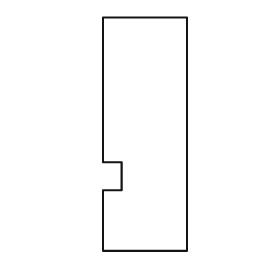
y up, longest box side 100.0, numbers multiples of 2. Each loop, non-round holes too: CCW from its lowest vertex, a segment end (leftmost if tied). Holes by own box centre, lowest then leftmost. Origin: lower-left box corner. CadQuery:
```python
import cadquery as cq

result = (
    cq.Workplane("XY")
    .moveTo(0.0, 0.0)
    .lineTo(36.0, 0.0)
    .lineTo(36.0, 100.0)
    .lineTo(0.0, 100.0)
    .lineTo(0.0, 38.0)
    .lineTo(8.0, 38.0)
    .lineTo(8.0, 26.0)
    .lineTo(0.0, 26.0)
    .close()
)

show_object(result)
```